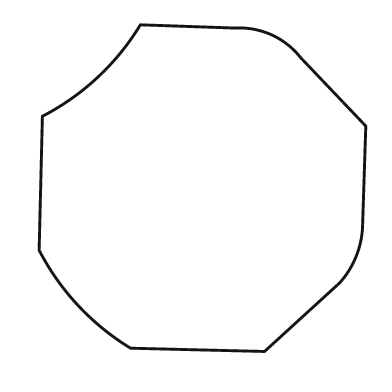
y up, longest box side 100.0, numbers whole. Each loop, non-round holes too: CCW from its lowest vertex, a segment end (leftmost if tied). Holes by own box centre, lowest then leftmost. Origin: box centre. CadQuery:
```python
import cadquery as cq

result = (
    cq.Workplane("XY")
    .moveTo(19.0, -50.0)
    .lineTo(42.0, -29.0)
    .threePointArc((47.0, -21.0), (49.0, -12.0))
    .lineTo(50.0, 19.0)
    .lineTo(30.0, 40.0)
    .threePointArc((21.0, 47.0), (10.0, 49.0))
    .lineTo(-19.0, 50.0)
    .threePointArc((-32.0, 34.0), (-49.0, 22.0))
    .lineTo(-50.0, -19.0)
    .threePointArc((-38.0, -36.0), (-22.0, -49.0))
    .close()
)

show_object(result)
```